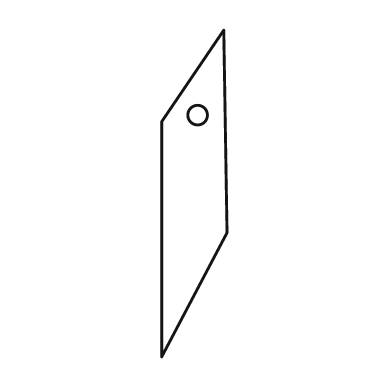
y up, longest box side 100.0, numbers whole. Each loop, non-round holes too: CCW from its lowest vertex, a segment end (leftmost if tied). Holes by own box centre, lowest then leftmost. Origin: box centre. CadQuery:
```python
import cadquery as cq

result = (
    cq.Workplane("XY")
    .moveTo(-10.0, -50.0)
    .lineTo(10.0, -12.0)
    .lineTo(9.0, 50.0)
    .lineTo(-10.0, 22.0)
    .close()
    .moveTo(1.0, 24.0)
    .circle(3.0)
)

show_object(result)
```